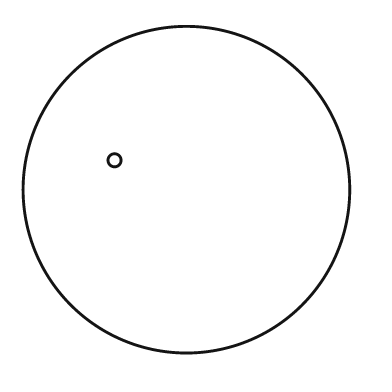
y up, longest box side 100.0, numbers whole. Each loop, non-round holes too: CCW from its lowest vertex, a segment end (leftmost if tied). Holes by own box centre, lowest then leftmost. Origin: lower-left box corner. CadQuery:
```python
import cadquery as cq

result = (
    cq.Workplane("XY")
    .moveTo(50.0, 50.0)
    .circle(50.0)
    .moveTo(28.0, 59.0)
    .circle(2.0)
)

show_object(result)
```